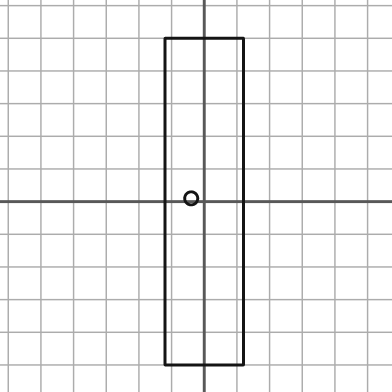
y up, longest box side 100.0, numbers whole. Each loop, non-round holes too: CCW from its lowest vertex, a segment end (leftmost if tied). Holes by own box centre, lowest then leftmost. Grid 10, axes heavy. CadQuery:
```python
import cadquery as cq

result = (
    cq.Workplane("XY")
    .moveTo(-12.0, -50.0)
    .lineTo(12.0, -50.0)
    .lineTo(12.0, 50.0)
    .lineTo(-12.0, 50.0)
    .close()
    .moveTo(-4.0, 1.0)
    .circle(2.0)
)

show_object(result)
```